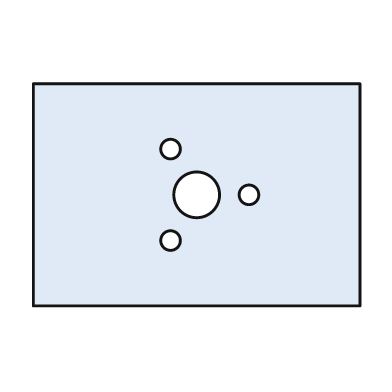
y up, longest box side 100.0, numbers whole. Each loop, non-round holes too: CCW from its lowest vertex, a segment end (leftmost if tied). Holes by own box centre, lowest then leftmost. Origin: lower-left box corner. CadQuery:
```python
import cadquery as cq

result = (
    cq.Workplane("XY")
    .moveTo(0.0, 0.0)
    .lineTo(100.0, 0.0)
    .lineTo(100.0, 68.0)
    .lineTo(0.0, 68.0)
    .close()
    .moveTo(42.0, 20.0)
    .circle(3.0)
    .moveTo(50.0, 34.0)
    .circle(7.0)
    .moveTo(66.0, 34.0)
    .circle(3.0)
    .moveTo(42.0, 48.0)
    .circle(3.0)
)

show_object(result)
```